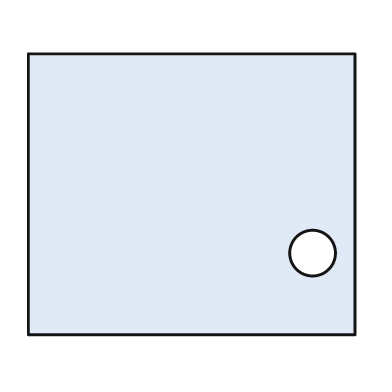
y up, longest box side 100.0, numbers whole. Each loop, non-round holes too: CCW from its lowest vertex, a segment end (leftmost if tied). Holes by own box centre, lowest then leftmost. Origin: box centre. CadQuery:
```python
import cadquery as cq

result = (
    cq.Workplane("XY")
    .moveTo(-50.0, -43.0)
    .lineTo(50.0, -43.0)
    .lineTo(50.0, 43.0)
    .lineTo(-50.0, 43.0)
    .close()
    .moveTo(37.0, -18.0)
    .circle(7.0)
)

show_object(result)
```